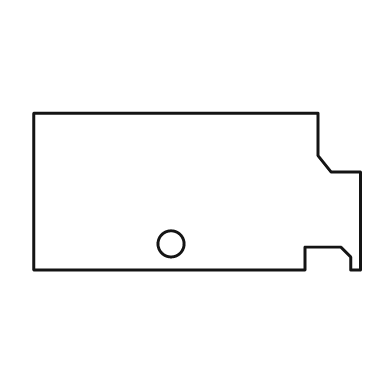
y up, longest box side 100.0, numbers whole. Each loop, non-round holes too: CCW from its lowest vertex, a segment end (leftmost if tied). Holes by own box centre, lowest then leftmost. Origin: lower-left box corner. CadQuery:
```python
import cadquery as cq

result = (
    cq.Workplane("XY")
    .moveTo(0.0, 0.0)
    .lineTo(83.0, 0.0)
    .lineTo(83.0, 7.0)
    .lineTo(94.0, 7.0)
    .lineTo(97.0, 4.0)
    .lineTo(97.0, 0.0)
    .lineTo(100.0, 0.0)
    .lineTo(100.0, 30.0)
    .lineTo(91.0, 30.0)
    .lineTo(87.0, 35.0)
    .lineTo(87.0, 48.0)
    .lineTo(0.0, 48.0)
    .close()
    .moveTo(42.0, 8.0)
    .circle(4.0)
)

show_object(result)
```